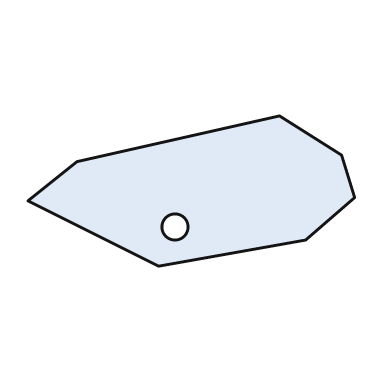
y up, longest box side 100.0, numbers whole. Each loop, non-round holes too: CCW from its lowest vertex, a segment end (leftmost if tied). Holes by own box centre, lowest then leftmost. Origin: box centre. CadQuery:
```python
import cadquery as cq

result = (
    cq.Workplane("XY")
    .moveTo(-10.0, -23.0)
    .lineTo(35.0, -15.0)
    .lineTo(50.0, -2.0)
    .lineTo(46.0, 11.0)
    .lineTo(27.0, 23.0)
    .lineTo(-35.0, 9.0)
    .lineTo(-50.0, -3.0)
    .close()
    .moveTo(-5.0, -11.0)
    .circle(4.0)
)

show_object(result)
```